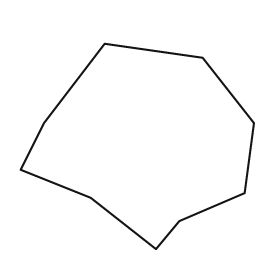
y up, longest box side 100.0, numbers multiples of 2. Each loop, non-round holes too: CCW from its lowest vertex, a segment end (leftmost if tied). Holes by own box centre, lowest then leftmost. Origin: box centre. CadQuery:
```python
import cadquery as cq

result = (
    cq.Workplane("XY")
    .moveTo(8.0, -44.0)
    .lineTo(18.0, -32.0)
    .lineTo(46.0, -20.0)
    .lineTo(50.0, 10.0)
    .lineTo(28.0, 38.0)
    .lineTo(-14.0, 44.0)
    .lineTo(-40.0, 10.0)
    .lineTo(-50.0, -10.0)
    .lineTo(-20.0, -22.0)
    .close()
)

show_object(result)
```